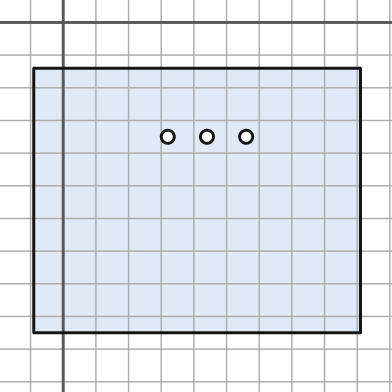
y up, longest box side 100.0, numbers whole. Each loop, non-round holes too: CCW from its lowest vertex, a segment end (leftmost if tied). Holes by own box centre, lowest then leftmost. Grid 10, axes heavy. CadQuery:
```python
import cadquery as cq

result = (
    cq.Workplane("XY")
    .moveTo(-9.0, -95.0)
    .lineTo(91.0, -95.0)
    .lineTo(91.0, -14.0)
    .lineTo(-9.0, -14.0)
    .close()
    .moveTo(32.0, -35.0)
    .circle(2.0)
    .moveTo(44.0, -35.0)
    .circle(2.0)
    .moveTo(56.0, -35.0)
    .circle(2.0)
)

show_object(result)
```